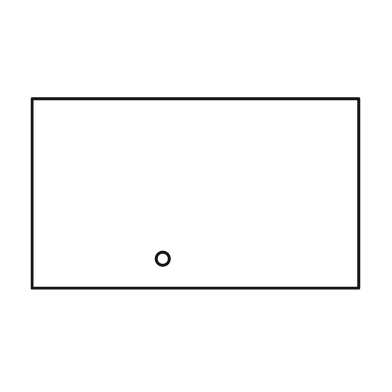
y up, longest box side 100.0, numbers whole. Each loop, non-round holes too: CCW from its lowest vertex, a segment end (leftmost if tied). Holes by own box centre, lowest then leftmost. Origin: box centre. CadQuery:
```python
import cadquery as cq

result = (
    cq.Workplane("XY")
    .moveTo(-50.0, -29.0)
    .lineTo(50.0, -29.0)
    .lineTo(50.0, 29.0)
    .lineTo(-50.0, 29.0)
    .close()
    .moveTo(-10.0, -20.0)
    .circle(2.0)
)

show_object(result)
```